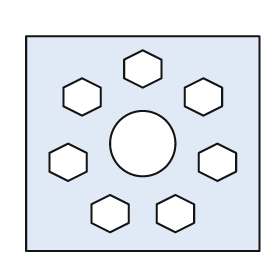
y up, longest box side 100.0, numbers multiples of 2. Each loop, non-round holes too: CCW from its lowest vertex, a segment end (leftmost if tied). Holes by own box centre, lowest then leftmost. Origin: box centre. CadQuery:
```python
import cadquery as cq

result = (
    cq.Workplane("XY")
    .moveTo(-50.0, -46.0)
    .lineTo(50.0, -46.0)
    .lineTo(50.0, 46.0)
    .lineTo(-50.0, 46.0)
    .close()
    .moveTo(-14.0, -38.0)
    .lineTo(-6.0, -34.0)
    .lineTo(-6.0, -26.0)
    .lineTo(-14.0, -22.0)
    .lineTo(-22.0, -26.0)
    .lineTo(-22.0, -34.0)
    .close()
    .moveTo(14.0, -38.0)
    .lineTo(22.0, -34.0)
    .lineTo(22.0, -26.0)
    .lineTo(14.0, -22.0)
    .lineTo(6.0, -26.0)
    .lineTo(6.0, -34.0)
    .close()
    .moveTo(-32.0, -16.0)
    .lineTo(-24.0, -12.0)
    .lineTo(-24.0, -4.0)
    .lineTo(-32.0, 0.0)
    .lineTo(-40.0, -4.0)
    .lineTo(-40.0, -12.0)
    .close()
    .moveTo(32.0, -16.0)
    .lineTo(40.0, -12.0)
    .lineTo(40.0, -4.0)
    .lineTo(32.0, 0.0)
    .lineTo(24.0, -4.0)
    .lineTo(24.0, -12.0)
    .close()
    .moveTo(0.0, 0.0)
    .circle(14.0)
    .moveTo(-26.0, 12.0)
    .lineTo(-18.0, 16.0)
    .lineTo(-18.0, 24.0)
    .lineTo(-26.0, 28.0)
    .lineTo(-34.0, 24.0)
    .lineTo(-34.0, 16.0)
    .close()
    .moveTo(26.0, 12.0)
    .lineTo(34.0, 16.0)
    .lineTo(34.0, 24.0)
    .lineTo(26.0, 28.0)
    .lineTo(18.0, 24.0)
    .lineTo(18.0, 16.0)
    .close()
    .moveTo(0.0, 24.0)
    .lineTo(8.0, 28.0)
    .lineTo(8.0, 36.0)
    .lineTo(0.0, 40.0)
    .lineTo(-8.0, 36.0)
    .lineTo(-8.0, 28.0)
    .close()
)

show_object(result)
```